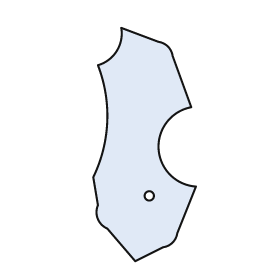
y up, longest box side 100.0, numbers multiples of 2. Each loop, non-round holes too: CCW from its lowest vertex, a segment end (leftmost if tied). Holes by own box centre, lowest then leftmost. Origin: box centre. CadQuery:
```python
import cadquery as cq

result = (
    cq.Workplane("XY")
    .moveTo(-4.0, -50.0)
    .lineTo(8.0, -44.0)
    .threePointArc((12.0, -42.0), (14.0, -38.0))
    .lineTo(22.0, -18.0)
    .threePointArc((6.0, -2.0), (20.0, 16.0))
    .lineTo(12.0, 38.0)
    .threePointArc((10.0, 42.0), (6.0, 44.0))
    .lineTo(-10.0, 50.0)
    .threePointArc((-12.0, 40.0), (-20.0, 34.0))
    .threePointArc((-16.0, 10.0), (-22.0, -14.0))
    .lineTo(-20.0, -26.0)
    .threePointArc((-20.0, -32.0), (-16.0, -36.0))
    .close()
    .moveTo(2.0, -22.0)
    .circle(2.0)
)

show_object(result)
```